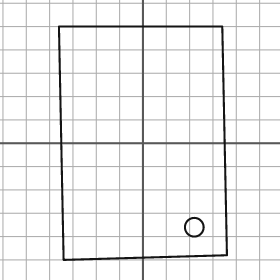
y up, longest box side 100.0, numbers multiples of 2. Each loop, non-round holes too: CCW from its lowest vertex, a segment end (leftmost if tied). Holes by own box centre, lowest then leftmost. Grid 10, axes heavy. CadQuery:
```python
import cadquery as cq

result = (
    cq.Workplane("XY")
    .moveTo(-34.0, -50.0)
    .lineTo(36.0, -48.0)
    .lineTo(34.0, 50.0)
    .lineTo(-36.0, 50.0)
    .close()
    .moveTo(22.0, -36.0)
    .circle(4.0)
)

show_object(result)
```